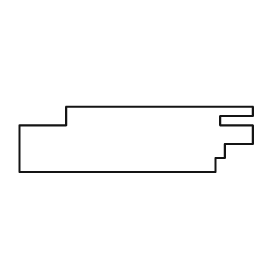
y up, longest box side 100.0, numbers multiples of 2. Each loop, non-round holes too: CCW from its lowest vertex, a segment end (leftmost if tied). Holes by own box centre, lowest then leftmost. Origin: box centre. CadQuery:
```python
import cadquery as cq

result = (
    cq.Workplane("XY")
    .moveTo(-50.0, -14.0)
    .lineTo(34.0, -14.0)
    .lineTo(34.0, -8.0)
    .lineTo(38.0, -8.0)
    .lineTo(38.0, -2.0)
    .lineTo(50.0, -2.0)
    .lineTo(50.0, 6.0)
    .lineTo(36.0, 6.0)
    .lineTo(36.0, 10.0)
    .lineTo(50.0, 10.0)
    .lineTo(50.0, 14.0)
    .lineTo(-30.0, 14.0)
    .lineTo(-30.0, 6.0)
    .lineTo(-50.0, 6.0)
    .close()
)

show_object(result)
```